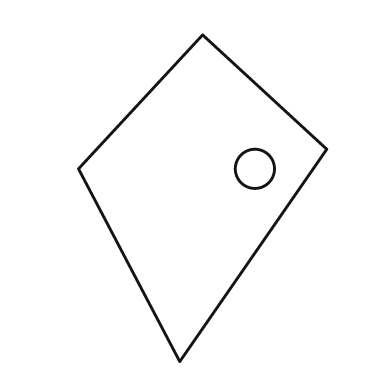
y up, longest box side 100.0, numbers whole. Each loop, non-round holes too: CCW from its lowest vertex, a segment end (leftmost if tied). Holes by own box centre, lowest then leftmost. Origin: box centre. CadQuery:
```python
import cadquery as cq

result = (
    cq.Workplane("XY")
    .moveTo(-7.0, -50.0)
    .lineTo(38.0, 15.0)
    .lineTo(0.0, 50.0)
    .lineTo(-38.0, 9.0)
    .close()
    .moveTo(16.0, 9.0)
    .circle(6.0)
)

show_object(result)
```